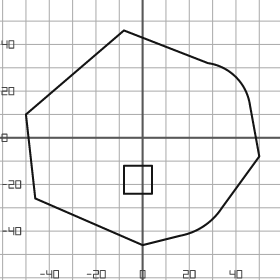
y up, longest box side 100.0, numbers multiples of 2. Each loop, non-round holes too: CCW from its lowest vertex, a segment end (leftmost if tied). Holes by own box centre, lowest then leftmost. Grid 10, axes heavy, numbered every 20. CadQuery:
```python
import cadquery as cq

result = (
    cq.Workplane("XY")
    .moveTo(0.0, -46.0)
    .lineTo(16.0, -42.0)
    .threePointArc((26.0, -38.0), (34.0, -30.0))
    .lineTo(50.0, -8.0)
    .lineTo(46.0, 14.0)
    .threePointArc((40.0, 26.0), (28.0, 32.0))
    .lineTo(-8.0, 46.0)
    .lineTo(-50.0, 10.0)
    .lineTo(-46.0, -26.0)
    .close()
    .moveTo(-8.0, -24.0)
    .lineTo(4.0, -24.0)
    .lineTo(4.0, -12.0)
    .lineTo(-8.0, -12.0)
    .close()
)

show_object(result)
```